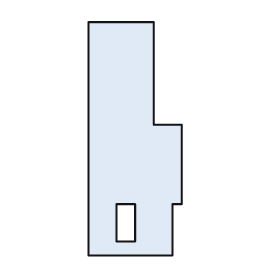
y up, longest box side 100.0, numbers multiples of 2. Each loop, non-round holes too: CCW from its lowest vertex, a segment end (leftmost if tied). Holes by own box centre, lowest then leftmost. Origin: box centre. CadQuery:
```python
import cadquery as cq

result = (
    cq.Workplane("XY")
    .moveTo(-20.0, -50.0)
    .lineTo(16.0, -50.0)
    .lineTo(16.0, -28.0)
    .lineTo(20.0, -28.0)
    .lineTo(20.0, 6.0)
    .lineTo(8.0, 6.0)
    .lineTo(8.0, 50.0)
    .lineTo(-20.0, 50.0)
    .close()
    .moveTo(-8.0, -44.0)
    .lineTo(0.0, -44.0)
    .lineTo(0.0, -28.0)
    .lineTo(-8.0, -28.0)
    .close()
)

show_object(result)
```